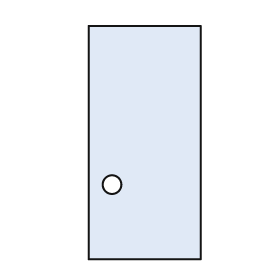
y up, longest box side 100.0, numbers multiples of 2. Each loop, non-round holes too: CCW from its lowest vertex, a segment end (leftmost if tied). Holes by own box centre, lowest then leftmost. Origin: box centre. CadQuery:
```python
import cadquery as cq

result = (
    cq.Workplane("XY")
    .moveTo(-24.0, -50.0)
    .lineTo(24.0, -50.0)
    .lineTo(24.0, 50.0)
    .lineTo(-24.0, 50.0)
    .close()
    .moveTo(-14.0, -18.0)
    .circle(4.0)
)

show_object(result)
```